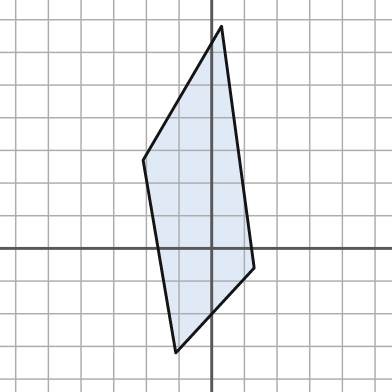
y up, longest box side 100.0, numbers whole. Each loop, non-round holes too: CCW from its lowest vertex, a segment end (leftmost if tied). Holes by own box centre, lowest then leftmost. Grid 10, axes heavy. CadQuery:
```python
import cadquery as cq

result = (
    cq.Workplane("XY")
    .moveTo(-11.0, -32.0)
    .lineTo(13.0, -6.0)
    .lineTo(3.0, 68.0)
    .lineTo(-21.0, 27.0)
    .close()
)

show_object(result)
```